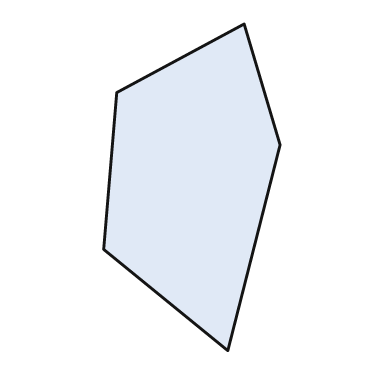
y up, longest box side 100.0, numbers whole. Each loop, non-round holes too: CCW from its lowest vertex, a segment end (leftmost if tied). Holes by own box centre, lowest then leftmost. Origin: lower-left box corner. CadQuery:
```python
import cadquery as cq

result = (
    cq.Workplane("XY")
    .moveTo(38.0, 0.0)
    .lineTo(54.0, 63.0)
    .lineTo(43.0, 100.0)
    .lineTo(4.0, 79.0)
    .lineTo(0.0, 31.0)
    .close()
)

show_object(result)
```